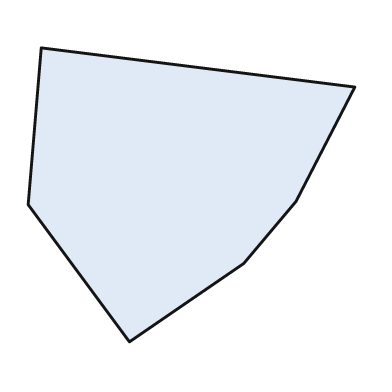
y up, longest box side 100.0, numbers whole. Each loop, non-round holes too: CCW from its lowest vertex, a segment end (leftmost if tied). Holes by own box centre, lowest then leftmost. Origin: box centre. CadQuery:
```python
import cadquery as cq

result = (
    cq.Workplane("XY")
    .moveTo(-19.0, -45.0)
    .lineTo(16.0, -21.0)
    .lineTo(32.0, -2.0)
    .lineTo(50.0, 33.0)
    .lineTo(-46.0, 45.0)
    .lineTo(-50.0, -3.0)
    .close()
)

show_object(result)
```